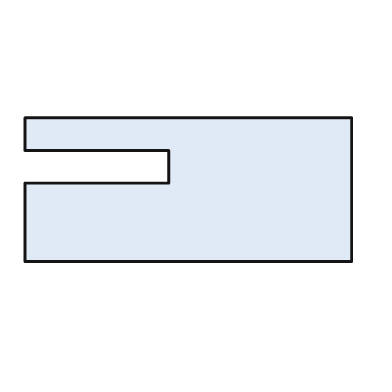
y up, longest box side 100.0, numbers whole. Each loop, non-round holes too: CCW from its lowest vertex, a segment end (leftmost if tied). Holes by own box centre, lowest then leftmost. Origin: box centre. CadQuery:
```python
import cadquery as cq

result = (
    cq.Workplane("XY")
    .moveTo(-50.0, -22.0)
    .lineTo(50.0, -22.0)
    .lineTo(50.0, 22.0)
    .lineTo(-50.0, 22.0)
    .lineTo(-50.0, 12.0)
    .lineTo(-6.0, 12.0)
    .lineTo(-6.0, 2.0)
    .lineTo(-50.0, 2.0)
    .close()
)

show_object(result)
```